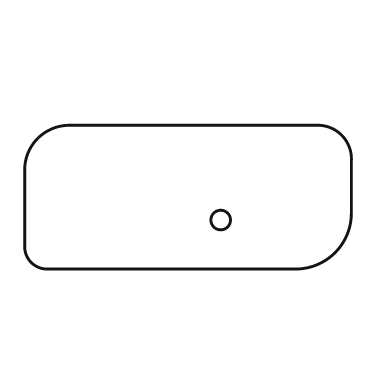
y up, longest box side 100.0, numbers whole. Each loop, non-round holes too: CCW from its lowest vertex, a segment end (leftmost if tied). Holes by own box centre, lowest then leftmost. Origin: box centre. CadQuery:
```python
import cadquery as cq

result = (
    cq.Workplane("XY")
    .moveTo(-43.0, -22.0)
    .lineTo(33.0, -22.0)
    .threePointArc((45.0, -17.0), (50.0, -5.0))
    .lineTo(50.0, 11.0)
    .threePointArc((47.0, 19.0), (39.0, 22.0))
    .lineTo(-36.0, 22.0)
    .threePointArc((-46.0, 18.0), (-50.0, 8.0))
    .lineTo(-50.0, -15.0)
    .threePointArc((-48.0, -20.0), (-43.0, -22.0))
    .close()
    .moveTo(10.0, -7.0)
    .circle(3.0)
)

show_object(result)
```